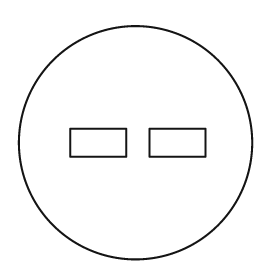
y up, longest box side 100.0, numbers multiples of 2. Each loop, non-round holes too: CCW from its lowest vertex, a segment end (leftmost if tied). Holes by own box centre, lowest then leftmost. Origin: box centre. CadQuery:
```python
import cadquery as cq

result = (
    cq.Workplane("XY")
    .moveTo(0.0, 0.0)
    .circle(50.0)
    .moveTo(-28.0, -6.0)
    .lineTo(-4.0, -6.0)
    .lineTo(-4.0, 6.0)
    .lineTo(-28.0, 6.0)
    .close()
    .moveTo(6.0, -6.0)
    .lineTo(30.0, -6.0)
    .lineTo(30.0, 6.0)
    .lineTo(6.0, 6.0)
    .close()
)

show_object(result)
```